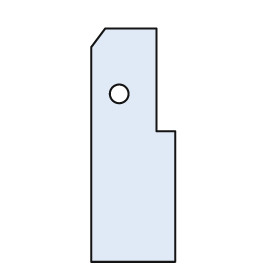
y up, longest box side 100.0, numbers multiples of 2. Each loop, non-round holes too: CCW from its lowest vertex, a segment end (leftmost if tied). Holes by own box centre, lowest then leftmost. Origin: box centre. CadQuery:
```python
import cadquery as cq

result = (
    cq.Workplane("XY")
    .moveTo(-18.0, -50.0)
    .lineTo(18.0, -50.0)
    .lineTo(18.0, 6.0)
    .lineTo(10.0, 6.0)
    .lineTo(10.0, 50.0)
    .lineTo(-12.0, 50.0)
    .lineTo(-18.0, 42.0)
    .close()
    .moveTo(-6.0, 22.0)
    .circle(4.0)
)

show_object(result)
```